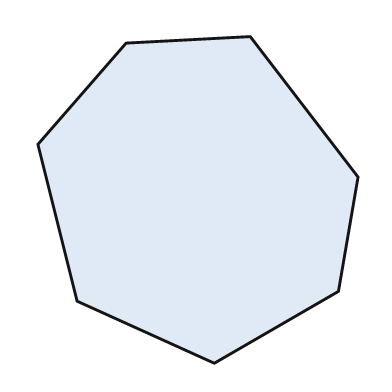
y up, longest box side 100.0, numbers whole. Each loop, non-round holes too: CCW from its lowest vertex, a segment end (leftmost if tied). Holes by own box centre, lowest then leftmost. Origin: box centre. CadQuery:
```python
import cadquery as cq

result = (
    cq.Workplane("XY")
    .moveTo(5.0, -50.0)
    .lineTo(43.0, -28.0)
    .lineTo(49.0, 7.0)
    .lineTo(16.0, 50.0)
    .lineTo(-22.0, 48.0)
    .lineTo(-49.0, 17.0)
    .lineTo(-37.0, -31.0)
    .close()
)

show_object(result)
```